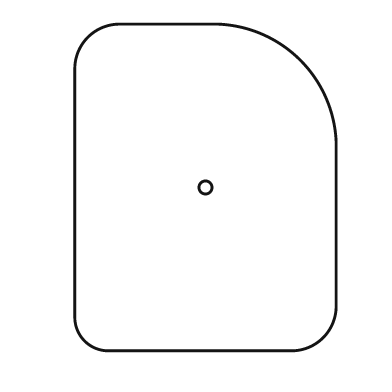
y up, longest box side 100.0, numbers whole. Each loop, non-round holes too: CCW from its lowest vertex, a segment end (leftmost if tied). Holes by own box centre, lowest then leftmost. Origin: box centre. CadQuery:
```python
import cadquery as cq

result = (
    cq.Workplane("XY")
    .moveTo(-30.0, -50.0)
    .lineTo(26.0, -50.0)
    .threePointArc((36.0, -46.0), (40.0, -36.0))
    .lineTo(40.0, 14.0)
    .threePointArc((29.0, 39.0), (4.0, 50.0))
    .lineTo(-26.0, 50.0)
    .threePointArc((-36.0, 46.0), (-40.0, 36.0))
    .lineTo(-40.0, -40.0)
    .threePointArc((-37.0, -47.0), (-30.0, -50.0))
    .close()
    .moveTo(0.0, 0.0)
    .circle(2.0)
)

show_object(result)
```